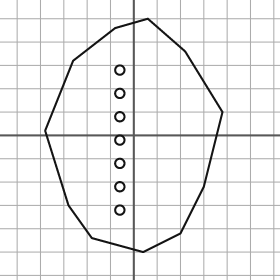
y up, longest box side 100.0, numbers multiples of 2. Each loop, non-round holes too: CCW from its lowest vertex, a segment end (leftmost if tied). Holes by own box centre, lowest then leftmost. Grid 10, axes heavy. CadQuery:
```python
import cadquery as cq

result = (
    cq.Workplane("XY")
    .moveTo(4.0, -50.0)
    .lineTo(20.0, -42.0)
    .lineTo(30.0, -22.0)
    .lineTo(38.0, 10.0)
    .lineTo(22.0, 36.0)
    .lineTo(6.0, 50.0)
    .lineTo(-8.0, 46.0)
    .lineTo(-26.0, 32.0)
    .lineTo(-38.0, 2.0)
    .lineTo(-28.0, -30.0)
    .lineTo(-18.0, -44.0)
    .close()
    .moveTo(-6.0, -32.0)
    .circle(2.0)
    .moveTo(-6.0, -22.0)
    .circle(2.0)
    .moveTo(-6.0, -12.0)
    .circle(2.0)
    .moveTo(-6.0, -2.0)
    .circle(2.0)
    .moveTo(-6.0, 8.0)
    .circle(2.0)
    .moveTo(-6.0, 18.0)
    .circle(2.0)
    .moveTo(-6.0, 28.0)
    .circle(2.0)
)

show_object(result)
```